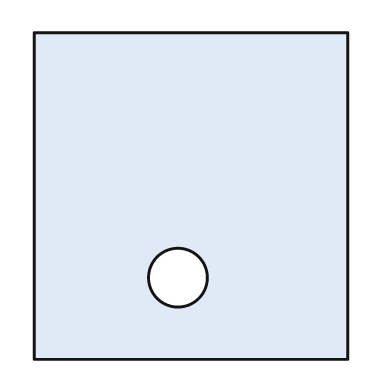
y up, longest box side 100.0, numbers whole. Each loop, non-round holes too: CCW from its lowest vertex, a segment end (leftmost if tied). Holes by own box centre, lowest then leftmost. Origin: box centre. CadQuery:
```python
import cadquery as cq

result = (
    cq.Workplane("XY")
    .moveTo(-48.0, -50.0)
    .lineTo(48.0, -50.0)
    .lineTo(48.0, 50.0)
    .lineTo(-48.0, 50.0)
    .close()
    .moveTo(-4.0, -25.0)
    .circle(9.0)
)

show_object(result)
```